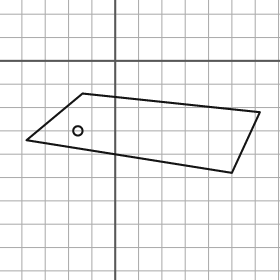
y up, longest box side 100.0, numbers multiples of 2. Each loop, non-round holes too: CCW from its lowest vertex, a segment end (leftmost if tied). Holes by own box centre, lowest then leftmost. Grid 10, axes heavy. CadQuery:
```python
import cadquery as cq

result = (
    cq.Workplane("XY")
    .moveTo(50.0, -48.0)
    .lineTo(62.0, -22.0)
    .lineTo(-14.0, -14.0)
    .lineTo(-38.0, -34.0)
    .close()
    .moveTo(-16.0, -30.0)
    .circle(2.0)
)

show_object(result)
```